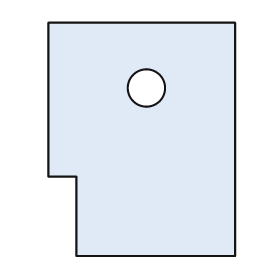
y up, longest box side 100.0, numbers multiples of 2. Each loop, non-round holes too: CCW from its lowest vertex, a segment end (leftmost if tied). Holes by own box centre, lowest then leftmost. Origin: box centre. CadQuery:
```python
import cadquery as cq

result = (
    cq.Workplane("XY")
    .moveTo(-28.0, -50.0)
    .lineTo(40.0, -50.0)
    .lineTo(40.0, 50.0)
    .lineTo(-40.0, 50.0)
    .lineTo(-40.0, -16.0)
    .lineTo(-28.0, -16.0)
    .close()
    .moveTo(2.0, 22.0)
    .circle(8.0)
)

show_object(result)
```